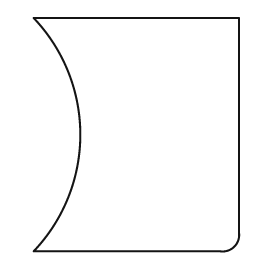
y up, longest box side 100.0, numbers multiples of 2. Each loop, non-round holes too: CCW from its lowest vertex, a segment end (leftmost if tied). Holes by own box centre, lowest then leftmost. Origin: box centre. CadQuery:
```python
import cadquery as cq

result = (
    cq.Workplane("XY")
    .moveTo(-44.0, -50.0)
    .lineTo(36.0, -50.0)
    .threePointArc((42.0, -48.0), (44.0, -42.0))
    .lineTo(44.0, 50.0)
    .lineTo(-44.0, 50.0)
    .threePointArc((-24.0, 0.0), (-44.0, -50.0))
    .close()
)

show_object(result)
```